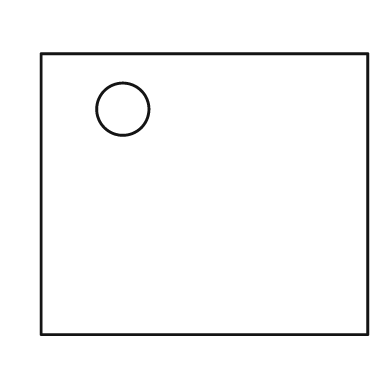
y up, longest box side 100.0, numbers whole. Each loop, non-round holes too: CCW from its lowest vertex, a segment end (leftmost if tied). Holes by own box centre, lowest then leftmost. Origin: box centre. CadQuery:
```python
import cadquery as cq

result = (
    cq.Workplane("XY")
    .moveTo(-50.0, -43.0)
    .lineTo(50.0, -43.0)
    .lineTo(50.0, 43.0)
    .lineTo(-50.0, 43.0)
    .close()
    .moveTo(-25.0, 26.0)
    .circle(8.0)
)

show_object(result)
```